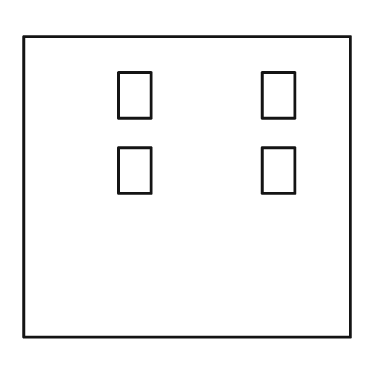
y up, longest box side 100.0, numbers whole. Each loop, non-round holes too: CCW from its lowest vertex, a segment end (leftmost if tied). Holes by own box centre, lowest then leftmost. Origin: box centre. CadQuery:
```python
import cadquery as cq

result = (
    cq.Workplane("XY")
    .moveTo(-50.0, -46.0)
    .lineTo(50.0, -46.0)
    .lineTo(50.0, 46.0)
    .lineTo(-50.0, 46.0)
    .close()
    .moveTo(-21.0, -2.0)
    .lineTo(-11.0, -2.0)
    .lineTo(-11.0, 12.0)
    .lineTo(-21.0, 12.0)
    .close()
    .moveTo(23.0, -2.0)
    .lineTo(33.0, -2.0)
    .lineTo(33.0, 12.0)
    .lineTo(23.0, 12.0)
    .close()
    .moveTo(-21.0, 21.0)
    .lineTo(-11.0, 21.0)
    .lineTo(-11.0, 35.0)
    .lineTo(-21.0, 35.0)
    .close()
    .moveTo(23.0, 21.0)
    .lineTo(33.0, 21.0)
    .lineTo(33.0, 35.0)
    .lineTo(23.0, 35.0)
    .close()
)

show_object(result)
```